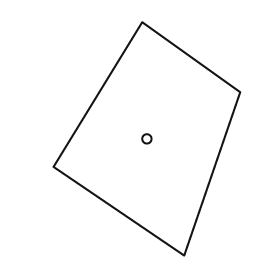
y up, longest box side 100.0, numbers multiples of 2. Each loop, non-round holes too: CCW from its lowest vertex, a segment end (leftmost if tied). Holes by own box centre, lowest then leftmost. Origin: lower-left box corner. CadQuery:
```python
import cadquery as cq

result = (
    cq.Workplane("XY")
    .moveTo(56.0, 0.0)
    .lineTo(80.0, 70.0)
    .lineTo(38.0, 100.0)
    .lineTo(0.0, 38.0)
    .close()
    .moveTo(40.0, 50.0)
    .circle(2.0)
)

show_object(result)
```